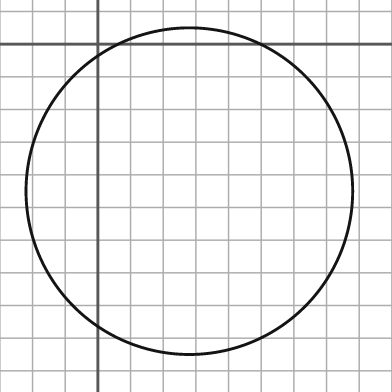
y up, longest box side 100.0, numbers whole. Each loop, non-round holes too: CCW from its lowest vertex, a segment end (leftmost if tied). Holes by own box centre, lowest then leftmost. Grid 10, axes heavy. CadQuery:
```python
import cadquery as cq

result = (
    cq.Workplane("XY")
    .moveTo(28.0, -45.0)
    .circle(50.0)
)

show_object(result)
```